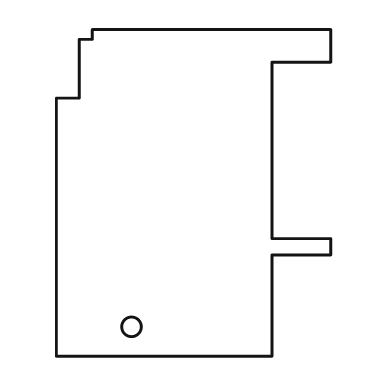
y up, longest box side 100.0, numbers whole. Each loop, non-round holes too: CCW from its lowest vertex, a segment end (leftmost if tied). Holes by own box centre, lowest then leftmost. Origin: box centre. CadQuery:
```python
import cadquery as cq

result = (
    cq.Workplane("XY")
    .moveTo(-42.0, -50.0)
    .lineTo(24.0, -50.0)
    .lineTo(24.0, -19.0)
    .lineTo(42.0, -19.0)
    .lineTo(42.0, -14.0)
    .lineTo(24.0, -14.0)
    .lineTo(24.0, 40.0)
    .lineTo(42.0, 40.0)
    .lineTo(42.0, 50.0)
    .lineTo(-31.0, 50.0)
    .lineTo(-31.0, 47.0)
    .lineTo(-35.0, 47.0)
    .lineTo(-35.0, 29.0)
    .lineTo(-42.0, 29.0)
    .close()
    .moveTo(-19.0, -41.0)
    .circle(3.0)
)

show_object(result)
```